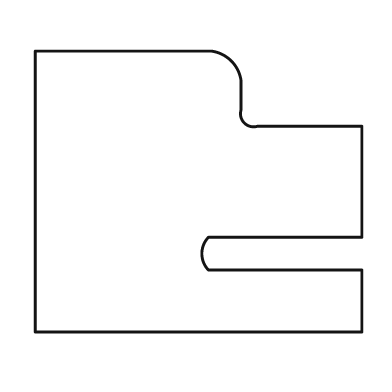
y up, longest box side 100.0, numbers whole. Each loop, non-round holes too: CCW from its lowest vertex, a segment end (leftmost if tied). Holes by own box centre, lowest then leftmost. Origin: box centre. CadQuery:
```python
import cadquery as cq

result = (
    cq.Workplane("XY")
    .moveTo(-50.0, -43.0)
    .lineTo(50.0, -43.0)
    .lineTo(50.0, -24.0)
    .lineTo(3.0, -24.0)
    .threePointArc((1.0, -19.0), (3.0, -14.0))
    .lineTo(50.0, -14.0)
    .lineTo(50.0, 20.0)
    .lineTo(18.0, 20.0)
    .threePointArc((14.0, 21.0), (13.0, 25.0))
    .lineTo(13.0, 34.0)
    .threePointArc((10.0, 40.0), (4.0, 43.0))
    .lineTo(-50.0, 43.0)
    .close()
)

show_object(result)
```